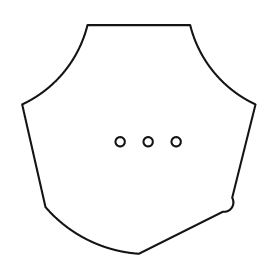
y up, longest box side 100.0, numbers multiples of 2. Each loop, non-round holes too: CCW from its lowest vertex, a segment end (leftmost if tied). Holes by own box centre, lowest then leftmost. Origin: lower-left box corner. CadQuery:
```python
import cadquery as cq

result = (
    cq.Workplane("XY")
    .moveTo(50.0, 0.0)
    .lineTo(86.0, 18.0)
    .threePointArc((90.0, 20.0), (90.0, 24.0))
    .lineTo(100.0, 64.0)
    .threePointArc((82.0, 78.0), (72.0, 98.0))
    .lineTo(28.0, 98.0)
    .threePointArc((18.0, 78.0), (0.0, 64.0))
    .lineTo(10.0, 20.0)
    .threePointArc((28.0, 6.0), (50.0, 0.0))
    .close()
    .moveTo(42.0, 48.0)
    .circle(2.0)
    .moveTo(54.0, 48.0)
    .circle(2.0)
    .moveTo(66.0, 48.0)
    .circle(2.0)
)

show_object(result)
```